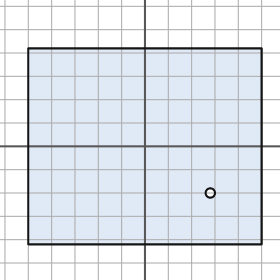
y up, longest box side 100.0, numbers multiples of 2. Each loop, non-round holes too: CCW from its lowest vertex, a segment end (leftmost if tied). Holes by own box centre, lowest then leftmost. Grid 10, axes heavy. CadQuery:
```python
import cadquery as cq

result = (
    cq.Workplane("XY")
    .moveTo(-50.0, -42.0)
    .lineTo(50.0, -42.0)
    .lineTo(50.0, 42.0)
    .lineTo(-50.0, 42.0)
    .close()
    .moveTo(28.0, -20.0)
    .circle(2.0)
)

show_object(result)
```